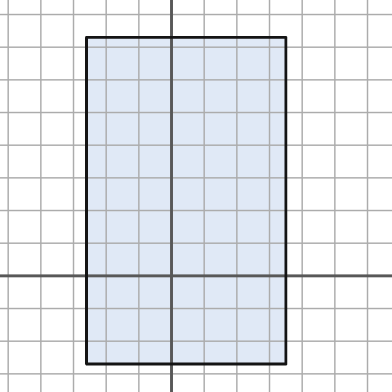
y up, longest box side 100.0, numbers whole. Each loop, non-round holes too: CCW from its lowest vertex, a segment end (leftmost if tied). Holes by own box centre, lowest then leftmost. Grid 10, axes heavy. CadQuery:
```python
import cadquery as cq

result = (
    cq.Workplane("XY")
    .moveTo(-26.0, -27.0)
    .lineTo(35.0, -27.0)
    .lineTo(35.0, 73.0)
    .lineTo(-26.0, 73.0)
    .close()
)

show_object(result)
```